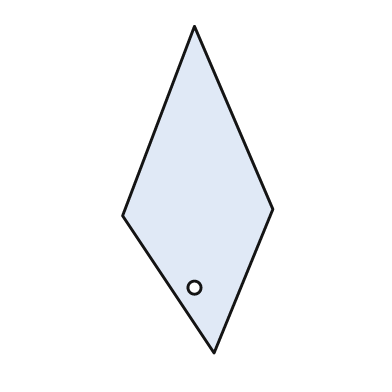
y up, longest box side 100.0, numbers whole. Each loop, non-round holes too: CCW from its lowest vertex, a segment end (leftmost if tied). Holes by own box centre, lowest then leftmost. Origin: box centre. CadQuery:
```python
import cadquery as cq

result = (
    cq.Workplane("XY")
    .moveTo(5.0, -50.0)
    .lineTo(23.0, -6.0)
    .lineTo(-1.0, 50.0)
    .lineTo(-23.0, -8.0)
    .close()
    .moveTo(-1.0, -30.0)
    .circle(2.0)
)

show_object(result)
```